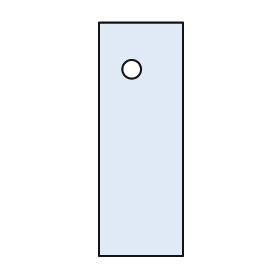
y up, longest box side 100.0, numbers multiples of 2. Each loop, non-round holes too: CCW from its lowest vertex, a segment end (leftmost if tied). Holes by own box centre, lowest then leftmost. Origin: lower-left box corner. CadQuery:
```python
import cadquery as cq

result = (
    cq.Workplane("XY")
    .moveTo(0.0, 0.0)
    .lineTo(36.0, 0.0)
    .lineTo(36.0, 100.0)
    .lineTo(0.0, 100.0)
    .close()
    .moveTo(14.0, 80.0)
    .circle(4.0)
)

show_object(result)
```